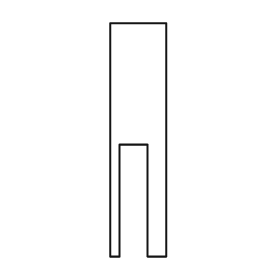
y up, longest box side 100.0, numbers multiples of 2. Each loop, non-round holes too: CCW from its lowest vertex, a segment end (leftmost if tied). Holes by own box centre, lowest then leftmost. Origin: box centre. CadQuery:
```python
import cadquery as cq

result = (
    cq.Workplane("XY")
    .moveTo(-12.0, -50.0)
    .lineTo(-8.0, -50.0)
    .lineTo(-8.0, -2.0)
    .lineTo(4.0, -2.0)
    .lineTo(4.0, -50.0)
    .lineTo(12.0, -50.0)
    .lineTo(12.0, 50.0)
    .lineTo(-12.0, 50.0)
    .close()
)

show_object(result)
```